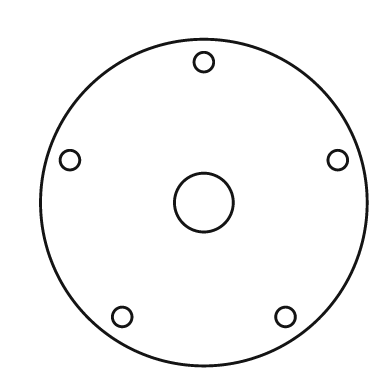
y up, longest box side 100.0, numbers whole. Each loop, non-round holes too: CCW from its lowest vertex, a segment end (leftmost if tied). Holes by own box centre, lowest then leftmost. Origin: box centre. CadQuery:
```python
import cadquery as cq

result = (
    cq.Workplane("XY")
    .moveTo(0.0, 0.0)
    .circle(50.0)
    .moveTo(-25.0, -35.0)
    .circle(3.0)
    .moveTo(25.0, -35.0)
    .circle(3.0)
    .moveTo(0.0, 0.0)
    .circle(9.0)
    .moveTo(-41.0, 13.0)
    .circle(3.0)
    .moveTo(41.0, 13.0)
    .circle(3.0)
    .moveTo(0.0, 43.0)
    .circle(3.0)
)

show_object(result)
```